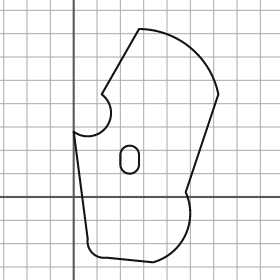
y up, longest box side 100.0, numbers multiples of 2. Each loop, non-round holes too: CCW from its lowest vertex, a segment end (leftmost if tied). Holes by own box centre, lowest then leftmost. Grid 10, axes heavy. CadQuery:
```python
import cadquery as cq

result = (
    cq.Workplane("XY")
    .moveTo(34.0, -28.0)
    .threePointArc((48.0, -16.0), (48.0, 2.0))
    .lineTo(62.0, 44.0)
    .threePointArc((50.0, 64.0), (28.0, 72.0))
    .lineTo(12.0, 44.0)
    .threePointArc((14.0, 30.0), (0.0, 28.0))
    .lineTo(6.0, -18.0)
    .threePointArc((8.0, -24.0), (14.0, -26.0))
    .close()
    .moveTo(20.0, 14.0)
    .threePointArc((24.0, 10.0), (28.0, 14.0))
    .lineTo(28.0, 18.0)
    .threePointArc((24.0, 22.0), (20.0, 18.0))
    .close()
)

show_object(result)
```